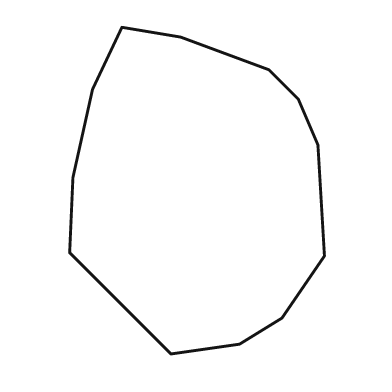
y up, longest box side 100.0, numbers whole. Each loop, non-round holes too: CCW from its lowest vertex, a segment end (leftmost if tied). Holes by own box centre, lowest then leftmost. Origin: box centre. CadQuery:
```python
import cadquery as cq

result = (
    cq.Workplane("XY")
    .moveTo(-8.0, -50.0)
    .lineTo(13.0, -47.0)
    .lineTo(26.0, -39.0)
    .lineTo(39.0, -20.0)
    .lineTo(37.0, 14.0)
    .lineTo(31.0, 28.0)
    .lineTo(22.0, 37.0)
    .lineTo(-5.0, 47.0)
    .lineTo(-23.0, 50.0)
    .lineTo(-32.0, 31.0)
    .lineTo(-38.0, 4.0)
    .lineTo(-39.0, -19.0)
    .close()
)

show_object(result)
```